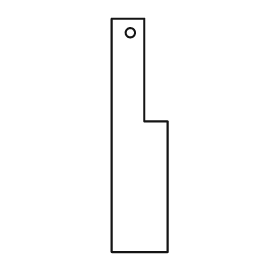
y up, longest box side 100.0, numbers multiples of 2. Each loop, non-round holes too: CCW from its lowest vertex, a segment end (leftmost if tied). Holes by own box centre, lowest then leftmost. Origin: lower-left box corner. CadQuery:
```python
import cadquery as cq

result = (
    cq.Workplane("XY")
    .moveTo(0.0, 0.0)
    .lineTo(24.0, 0.0)
    .lineTo(24.0, 56.0)
    .lineTo(14.0, 56.0)
    .lineTo(14.0, 100.0)
    .lineTo(0.0, 100.0)
    .close()
    .moveTo(8.0, 94.0)
    .circle(2.0)
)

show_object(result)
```